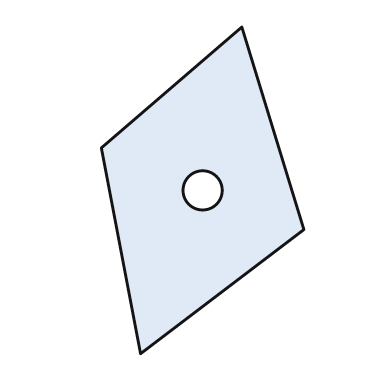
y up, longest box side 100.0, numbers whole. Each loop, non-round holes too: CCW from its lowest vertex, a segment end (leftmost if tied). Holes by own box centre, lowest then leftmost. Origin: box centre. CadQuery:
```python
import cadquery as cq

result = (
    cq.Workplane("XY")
    .moveTo(-19.0, -50.0)
    .lineTo(31.0, -12.0)
    .lineTo(12.0, 50.0)
    .lineTo(-31.0, 13.0)
    .close()
    .moveTo(0.0, 0.0)
    .circle(6.0)
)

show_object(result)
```